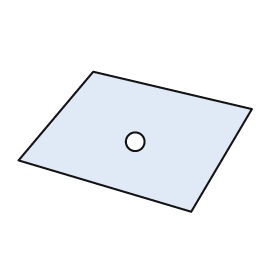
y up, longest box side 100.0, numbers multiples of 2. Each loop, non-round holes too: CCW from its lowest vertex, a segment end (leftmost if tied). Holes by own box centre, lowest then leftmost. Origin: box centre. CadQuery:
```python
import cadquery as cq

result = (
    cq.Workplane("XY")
    .moveTo(24.0, -30.0)
    .lineTo(50.0, 14.0)
    .lineTo(-18.0, 30.0)
    .lineTo(-50.0, -8.0)
    .close()
    .moveTo(0.0, 0.0)
    .circle(4.0)
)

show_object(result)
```